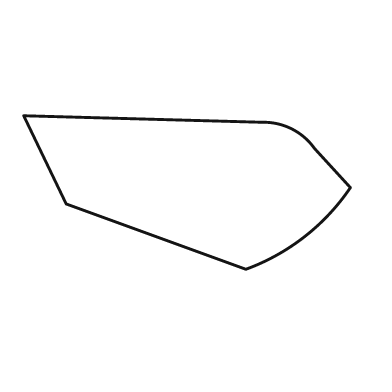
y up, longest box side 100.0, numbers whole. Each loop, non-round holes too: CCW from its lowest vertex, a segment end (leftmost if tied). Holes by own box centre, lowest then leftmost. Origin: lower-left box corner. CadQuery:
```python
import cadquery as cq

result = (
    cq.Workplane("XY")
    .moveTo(68.0, 0.0)
    .threePointArc((86.0, 10.0), (100.0, 25.0))
    .lineTo(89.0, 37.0)
    .threePointArc((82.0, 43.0), (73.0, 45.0))
    .lineTo(0.0, 47.0)
    .lineTo(13.0, 20.0)
    .close()
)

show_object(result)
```